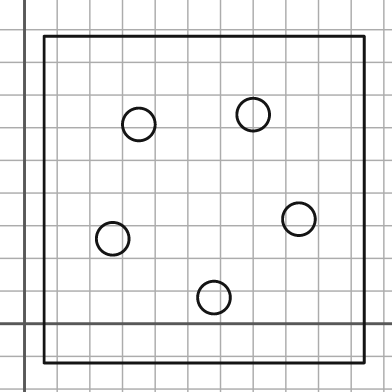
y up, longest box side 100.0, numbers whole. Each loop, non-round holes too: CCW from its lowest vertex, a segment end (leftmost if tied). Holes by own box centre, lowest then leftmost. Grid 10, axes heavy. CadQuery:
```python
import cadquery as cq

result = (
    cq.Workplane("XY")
    .moveTo(6.0, -12.0)
    .lineTo(104.0, -12.0)
    .lineTo(104.0, 88.0)
    .lineTo(6.0, 88.0)
    .close()
    .moveTo(58.0, 8.0)
    .circle(5.0)
    .moveTo(27.0, 26.0)
    .circle(5.0)
    .moveTo(84.0, 32.0)
    .circle(5.0)
    .moveTo(35.0, 61.0)
    .circle(5.0)
    .moveTo(70.0, 64.0)
    .circle(5.0)
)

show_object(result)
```